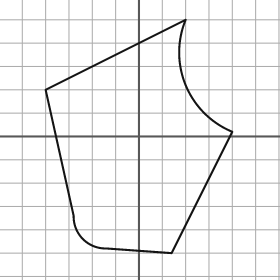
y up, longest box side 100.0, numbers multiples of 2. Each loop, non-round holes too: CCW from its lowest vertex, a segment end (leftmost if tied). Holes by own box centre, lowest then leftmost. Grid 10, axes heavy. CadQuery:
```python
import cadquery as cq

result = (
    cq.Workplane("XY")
    .moveTo(14.0, -50.0)
    .lineTo(40.0, 2.0)
    .threePointArc((20.0, 22.0), (20.0, 50.0))
    .lineTo(-40.0, 20.0)
    .lineTo(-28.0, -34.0)
    .threePointArc((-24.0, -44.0), (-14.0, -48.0))
    .close()
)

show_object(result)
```